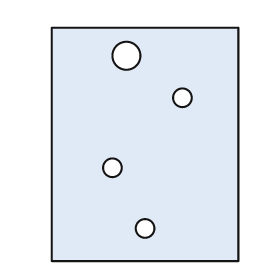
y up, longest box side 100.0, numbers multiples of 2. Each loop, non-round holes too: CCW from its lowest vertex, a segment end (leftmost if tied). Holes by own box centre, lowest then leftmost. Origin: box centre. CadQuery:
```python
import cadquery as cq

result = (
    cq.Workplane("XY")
    .moveTo(-40.0, -50.0)
    .lineTo(40.0, -50.0)
    .lineTo(40.0, 50.0)
    .lineTo(-40.0, 50.0)
    .close()
    .moveTo(0.0, -36.0)
    .circle(4.0)
    .moveTo(-14.0, -10.0)
    .circle(4.0)
    .moveTo(16.0, 20.0)
    .circle(4.0)
    .moveTo(-8.0, 38.0)
    .circle(6.0)
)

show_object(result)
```